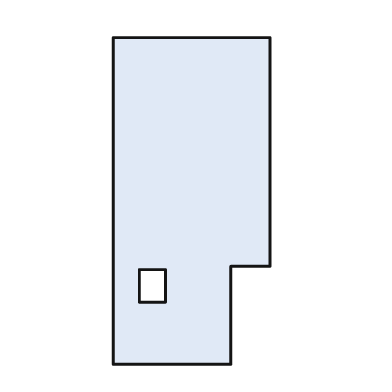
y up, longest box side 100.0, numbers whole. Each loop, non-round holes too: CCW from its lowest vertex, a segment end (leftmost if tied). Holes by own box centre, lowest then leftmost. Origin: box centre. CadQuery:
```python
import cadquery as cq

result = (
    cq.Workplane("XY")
    .moveTo(-24.0, -50.0)
    .lineTo(12.0, -50.0)
    .lineTo(12.0, -20.0)
    .lineTo(24.0, -20.0)
    .lineTo(24.0, 50.0)
    .lineTo(-24.0, 50.0)
    .close()
    .moveTo(-16.0, -31.0)
    .lineTo(-8.0, -31.0)
    .lineTo(-8.0, -21.0)
    .lineTo(-16.0, -21.0)
    .close()
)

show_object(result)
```